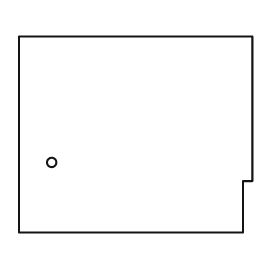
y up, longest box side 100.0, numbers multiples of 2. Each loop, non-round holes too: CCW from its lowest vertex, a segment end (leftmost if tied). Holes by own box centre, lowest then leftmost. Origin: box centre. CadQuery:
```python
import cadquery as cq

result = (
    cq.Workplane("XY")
    .moveTo(-50.0, -42.0)
    .lineTo(46.0, -42.0)
    .lineTo(46.0, -20.0)
    .lineTo(50.0, -20.0)
    .lineTo(50.0, 42.0)
    .lineTo(-50.0, 42.0)
    .close()
    .moveTo(-36.0, -12.0)
    .circle(2.0)
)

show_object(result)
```